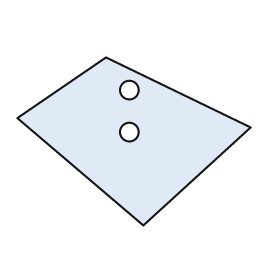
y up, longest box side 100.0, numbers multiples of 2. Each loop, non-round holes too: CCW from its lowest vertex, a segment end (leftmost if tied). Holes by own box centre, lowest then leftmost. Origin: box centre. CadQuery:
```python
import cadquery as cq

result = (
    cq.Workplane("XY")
    .moveTo(4.0, -36.0)
    .lineTo(50.0, 6.0)
    .lineTo(-12.0, 36.0)
    .lineTo(-50.0, 10.0)
    .close()
    .moveTo(-2.0, 4.0)
    .circle(4.0)
    .moveTo(-2.0, 22.0)
    .circle(4.0)
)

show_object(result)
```